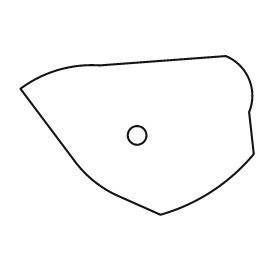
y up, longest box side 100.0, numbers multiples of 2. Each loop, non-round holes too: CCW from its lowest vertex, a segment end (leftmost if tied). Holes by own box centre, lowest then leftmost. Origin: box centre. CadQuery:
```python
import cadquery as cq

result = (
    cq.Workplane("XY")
    .moveTo(10.0, -34.0)
    .threePointArc((32.0, -24.0), (50.0, -8.0))
    .lineTo(48.0, 10.0)
    .threePointArc((48.0, 24.0), (38.0, 34.0))
    .lineTo(-16.0, 30.0)
    .threePointArc((-34.0, 28.0), (-50.0, 20.0))
    .lineTo(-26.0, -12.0)
    .threePointArc((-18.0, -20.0), (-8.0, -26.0))
    .close()
    .moveTo(0.0, 0.0)
    .circle(4.0)
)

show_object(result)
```